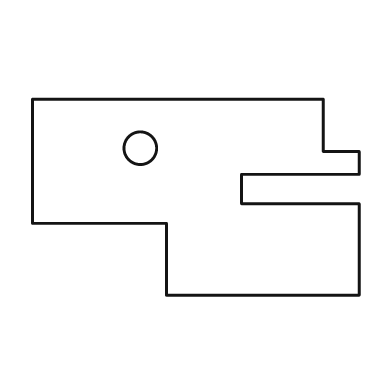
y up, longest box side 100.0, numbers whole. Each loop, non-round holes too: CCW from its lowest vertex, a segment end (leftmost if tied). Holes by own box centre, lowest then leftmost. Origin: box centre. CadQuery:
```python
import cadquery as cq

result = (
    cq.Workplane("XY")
    .moveTo(-9.0, -30.0)
    .lineTo(50.0, -30.0)
    .lineTo(50.0, -2.0)
    .lineTo(14.0, -2.0)
    .lineTo(14.0, 7.0)
    .lineTo(50.0, 7.0)
    .lineTo(50.0, 14.0)
    .lineTo(39.0, 14.0)
    .lineTo(39.0, 30.0)
    .lineTo(-50.0, 30.0)
    .lineTo(-50.0, -8.0)
    .lineTo(-9.0, -8.0)
    .close()
    .moveTo(-17.0, 15.0)
    .circle(5.0)
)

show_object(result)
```